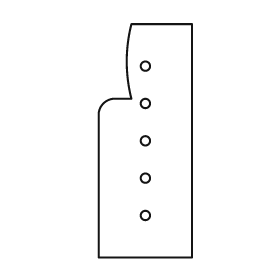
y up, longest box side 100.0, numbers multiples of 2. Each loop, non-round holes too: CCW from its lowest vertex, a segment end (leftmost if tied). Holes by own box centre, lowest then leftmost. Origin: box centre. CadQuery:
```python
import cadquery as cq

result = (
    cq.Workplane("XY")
    .moveTo(-20.0, -50.0)
    .lineTo(20.0, -50.0)
    .lineTo(20.0, 50.0)
    .lineTo(-6.0, 50.0)
    .threePointArc((-8.0, 34.0), (-6.0, 18.0))
    .lineTo(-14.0, 18.0)
    .threePointArc((-18.0, 16.0), (-20.0, 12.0))
    .close()
    .moveTo(0.0, -32.0)
    .circle(2.0)
    .moveTo(0.0, -16.0)
    .circle(2.0)
    .moveTo(0.0, 0.0)
    .circle(2.0)
    .moveTo(0.0, 16.0)
    .circle(2.0)
    .moveTo(0.0, 32.0)
    .circle(2.0)
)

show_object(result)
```